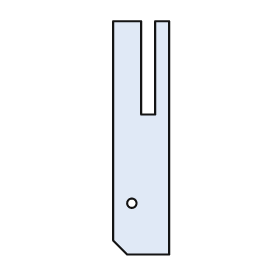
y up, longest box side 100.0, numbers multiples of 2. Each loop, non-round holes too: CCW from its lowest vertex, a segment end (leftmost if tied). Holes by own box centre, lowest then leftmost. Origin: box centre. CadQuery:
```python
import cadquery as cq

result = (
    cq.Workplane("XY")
    .moveTo(-6.0, -50.0)
    .lineTo(12.0, -50.0)
    .lineTo(12.0, 50.0)
    .lineTo(6.0, 50.0)
    .lineTo(6.0, 10.0)
    .lineTo(0.0, 10.0)
    .lineTo(0.0, 50.0)
    .lineTo(-12.0, 50.0)
    .lineTo(-12.0, -44.0)
    .close()
    .moveTo(-4.0, -28.0)
    .circle(2.0)
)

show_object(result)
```